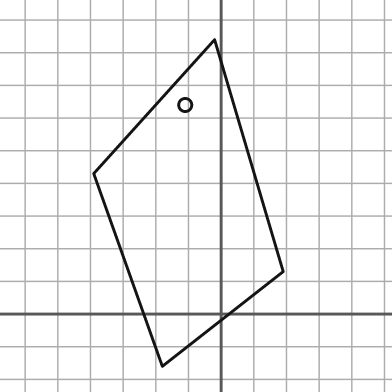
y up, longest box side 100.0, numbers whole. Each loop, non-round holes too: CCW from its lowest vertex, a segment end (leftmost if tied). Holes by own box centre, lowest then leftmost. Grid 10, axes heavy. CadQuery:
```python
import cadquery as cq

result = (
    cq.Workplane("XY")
    .moveTo(-18.0, -16.0)
    .lineTo(19.0, 13.0)
    .lineTo(-2.0, 84.0)
    .lineTo(-39.0, 43.0)
    .close()
    .moveTo(-11.0, 64.0)
    .circle(2.0)
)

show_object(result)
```